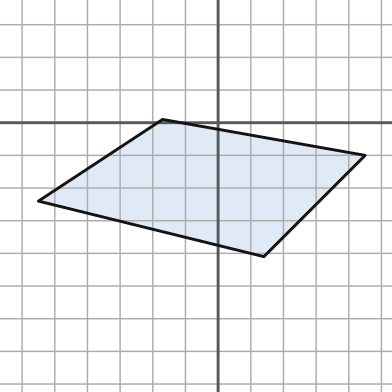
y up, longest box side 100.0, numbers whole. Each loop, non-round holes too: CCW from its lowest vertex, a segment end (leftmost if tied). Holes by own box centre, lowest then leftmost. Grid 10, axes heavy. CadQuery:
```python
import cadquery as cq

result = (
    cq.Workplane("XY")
    .moveTo(14.0, -41.0)
    .lineTo(45.0, -10.0)
    .lineTo(-17.0, 1.0)
    .lineTo(-55.0, -24.0)
    .close()
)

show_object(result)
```